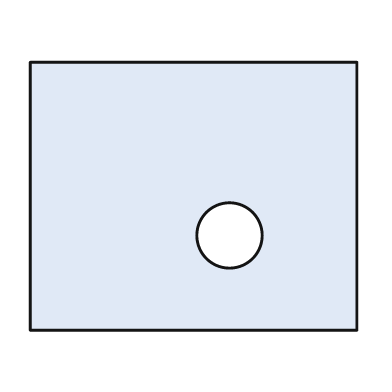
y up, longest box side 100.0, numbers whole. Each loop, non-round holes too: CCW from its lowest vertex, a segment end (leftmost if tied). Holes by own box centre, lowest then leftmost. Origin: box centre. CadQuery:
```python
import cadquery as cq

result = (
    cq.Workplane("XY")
    .moveTo(-50.0, -41.0)
    .lineTo(50.0, -41.0)
    .lineTo(50.0, 41.0)
    .lineTo(-50.0, 41.0)
    .close()
    .moveTo(11.0, -12.0)
    .circle(10.0)
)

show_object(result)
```